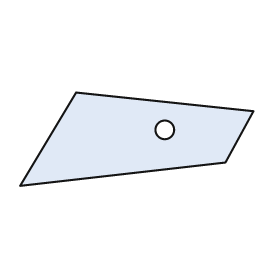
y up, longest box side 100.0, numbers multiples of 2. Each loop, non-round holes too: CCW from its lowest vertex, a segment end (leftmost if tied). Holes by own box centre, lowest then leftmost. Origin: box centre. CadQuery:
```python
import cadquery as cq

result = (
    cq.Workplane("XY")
    .moveTo(-50.0, -20.0)
    .lineTo(38.0, -10.0)
    .lineTo(50.0, 12.0)
    .lineTo(-26.0, 20.0)
    .close()
    .moveTo(12.0, 4.0)
    .circle(4.0)
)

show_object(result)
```